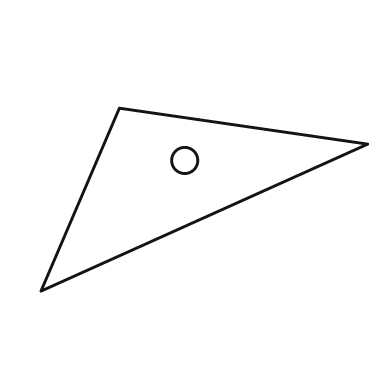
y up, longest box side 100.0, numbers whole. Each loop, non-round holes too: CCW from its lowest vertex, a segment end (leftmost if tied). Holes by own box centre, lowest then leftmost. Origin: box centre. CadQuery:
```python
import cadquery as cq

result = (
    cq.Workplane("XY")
    .moveTo(-50.0, -28.0)
    .lineTo(50.0, 17.0)
    .lineTo(-26.0, 28.0)
    .close()
    .moveTo(-6.0, 12.0)
    .circle(4.0)
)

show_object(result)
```